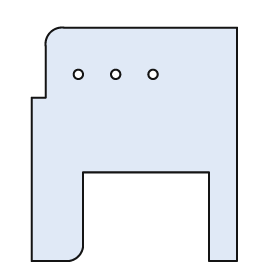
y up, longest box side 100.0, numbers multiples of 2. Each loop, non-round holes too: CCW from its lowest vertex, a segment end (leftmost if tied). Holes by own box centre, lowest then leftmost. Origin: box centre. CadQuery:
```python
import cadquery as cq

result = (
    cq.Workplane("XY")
    .moveTo(-44.0, -50.0)
    .lineTo(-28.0, -50.0)
    .threePointArc((-24.0, -48.0), (-22.0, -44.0))
    .lineTo(-22.0, -12.0)
    .lineTo(32.0, -12.0)
    .lineTo(32.0, -50.0)
    .lineTo(44.0, -50.0)
    .lineTo(44.0, 50.0)
    .lineTo(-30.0, 50.0)
    .threePointArc((-36.0, 48.0), (-38.0, 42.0))
    .lineTo(-38.0, 20.0)
    .lineTo(-44.0, 20.0)
    .close()
    .moveTo(-24.0, 30.0)
    .circle(2.0)
    .moveTo(-8.0, 30.0)
    .circle(2.0)
    .moveTo(8.0, 30.0)
    .circle(2.0)
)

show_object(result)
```